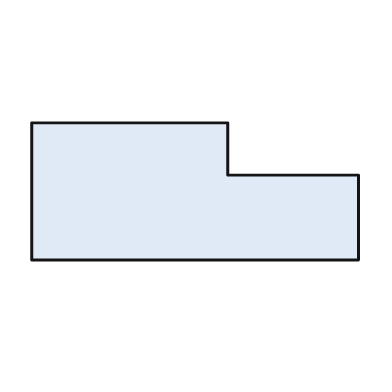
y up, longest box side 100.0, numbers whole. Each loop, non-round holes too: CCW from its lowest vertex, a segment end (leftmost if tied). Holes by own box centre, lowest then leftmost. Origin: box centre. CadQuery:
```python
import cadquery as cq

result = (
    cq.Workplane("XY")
    .moveTo(-50.0, -21.0)
    .lineTo(50.0, -21.0)
    .lineTo(50.0, 5.0)
    .lineTo(10.0, 5.0)
    .lineTo(10.0, 21.0)
    .lineTo(-50.0, 21.0)
    .close()
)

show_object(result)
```